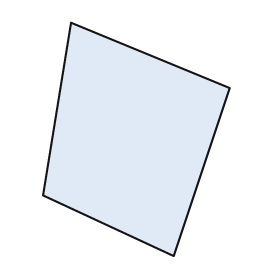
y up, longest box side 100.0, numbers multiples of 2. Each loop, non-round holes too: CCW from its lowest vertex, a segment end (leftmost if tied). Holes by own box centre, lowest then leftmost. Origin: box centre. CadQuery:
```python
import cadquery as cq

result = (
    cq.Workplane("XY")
    .moveTo(16.0, -50.0)
    .lineTo(40.0, 22.0)
    .lineTo(-28.0, 50.0)
    .lineTo(-40.0, -24.0)
    .close()
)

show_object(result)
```